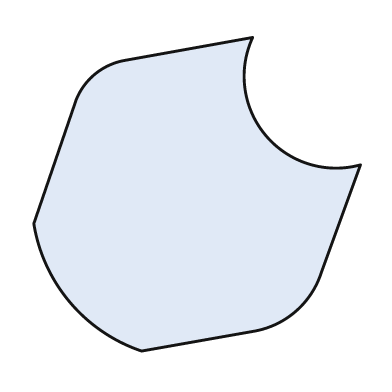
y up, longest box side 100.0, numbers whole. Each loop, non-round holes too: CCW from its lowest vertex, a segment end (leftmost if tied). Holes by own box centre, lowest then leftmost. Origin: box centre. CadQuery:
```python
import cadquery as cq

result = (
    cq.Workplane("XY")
    .moveTo(-17.0, -48.0)
    .lineTo(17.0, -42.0)
    .threePointArc((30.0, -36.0), (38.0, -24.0))
    .lineTo(50.0, 9.0)
    .threePointArc((21.0, 18.0), (17.0, 48.0))
    .lineTo(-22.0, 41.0)
    .threePointArc((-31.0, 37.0), (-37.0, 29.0))
    .lineTo(-50.0, -9.0)
    .threePointArc((-39.0, -33.0), (-17.0, -48.0))
    .close()
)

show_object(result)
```